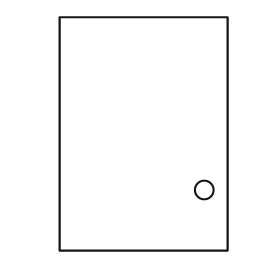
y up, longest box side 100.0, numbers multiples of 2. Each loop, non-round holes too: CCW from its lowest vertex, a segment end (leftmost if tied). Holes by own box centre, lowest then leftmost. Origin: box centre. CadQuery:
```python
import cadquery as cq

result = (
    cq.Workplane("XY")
    .moveTo(-36.0, -50.0)
    .lineTo(36.0, -50.0)
    .lineTo(36.0, 50.0)
    .lineTo(-36.0, 50.0)
    .close()
    .moveTo(26.0, -24.0)
    .circle(4.0)
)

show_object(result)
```